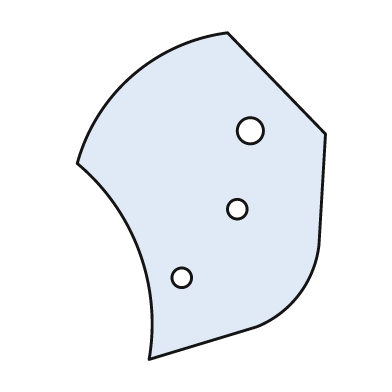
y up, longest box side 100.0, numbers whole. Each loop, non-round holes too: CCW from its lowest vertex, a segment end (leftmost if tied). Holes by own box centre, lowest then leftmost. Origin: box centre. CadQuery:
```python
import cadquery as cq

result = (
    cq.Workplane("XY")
    .moveTo(-16.0, -50.0)
    .lineTo(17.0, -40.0)
    .threePointArc((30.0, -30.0), (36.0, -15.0))
    .lineTo(38.0, 19.0)
    .lineTo(8.0, 50.0)
    .threePointArc((-21.0, 37.0), (-38.0, 10.0))
    .threePointArc((-19.0, -17.0), (-16.0, -50.0))
    .close()
    .moveTo(-6.0, -25.0)
    .circle(3.0)
    .moveTo(11.0, -4.0)
    .circle(3.0)
    .moveTo(15.0, 20.0)
    .circle(4.0)
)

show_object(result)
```